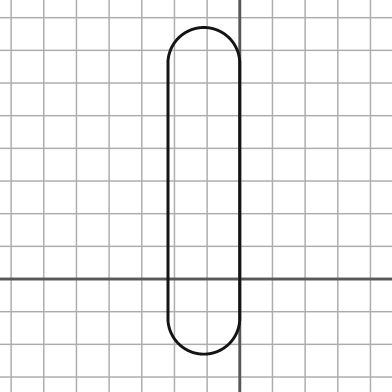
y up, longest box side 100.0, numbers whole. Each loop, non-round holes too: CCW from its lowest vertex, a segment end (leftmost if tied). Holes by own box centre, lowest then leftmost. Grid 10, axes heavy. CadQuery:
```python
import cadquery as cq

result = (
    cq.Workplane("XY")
    .moveTo(-22.0, -12.0)
    .threePointArc((-11.0, -23.0), (0.0, -12.0))
    .lineTo(0.0, 66.0)
    .threePointArc((-11.0, 77.0), (-22.0, 66.0))
    .close()
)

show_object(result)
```